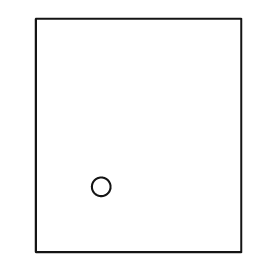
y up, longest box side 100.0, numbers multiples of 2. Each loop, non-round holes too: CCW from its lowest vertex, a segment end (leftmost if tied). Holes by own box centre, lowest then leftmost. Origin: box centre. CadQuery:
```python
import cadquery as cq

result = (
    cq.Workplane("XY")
    .moveTo(-44.0, -50.0)
    .lineTo(44.0, -50.0)
    .lineTo(44.0, 50.0)
    .lineTo(-44.0, 50.0)
    .close()
    .moveTo(-16.0, -22.0)
    .circle(4.0)
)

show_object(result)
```